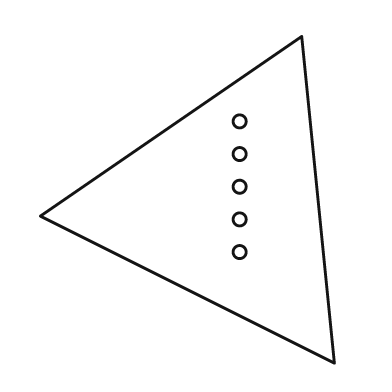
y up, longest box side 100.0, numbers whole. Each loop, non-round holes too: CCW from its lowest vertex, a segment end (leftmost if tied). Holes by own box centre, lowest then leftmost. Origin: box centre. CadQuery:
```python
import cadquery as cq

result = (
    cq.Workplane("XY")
    .moveTo(45.0, -50.0)
    .lineTo(35.0, 50.0)
    .lineTo(-45.0, -5.0)
    .close()
    .moveTo(16.0, -16.0)
    .circle(2.0)
    .moveTo(16.0, -6.0)
    .circle(2.0)
    .moveTo(16.0, 4.0)
    .circle(2.0)
    .moveTo(16.0, 14.0)
    .circle(2.0)
    .moveTo(16.0, 24.0)
    .circle(2.0)
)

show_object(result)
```